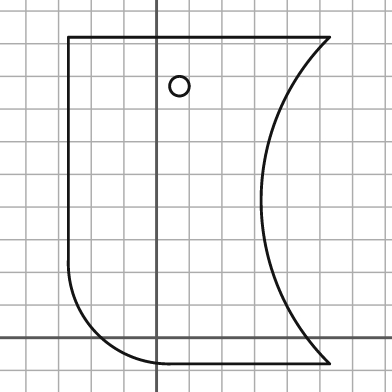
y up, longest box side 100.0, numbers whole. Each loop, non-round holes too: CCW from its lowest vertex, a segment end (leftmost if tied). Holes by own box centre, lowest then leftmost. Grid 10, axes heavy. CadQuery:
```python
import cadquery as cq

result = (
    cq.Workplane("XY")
    .moveTo(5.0, -8.0)
    .lineTo(53.0, -8.0)
    .threePointArc((32.0, 42.0), (53.0, 92.0))
    .lineTo(-27.0, 92.0)
    .lineTo(-27.0, 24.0)
    .threePointArc((-18.0, 1.0), (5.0, -8.0))
    .close()
    .moveTo(7.0, 77.0)
    .circle(3.0)
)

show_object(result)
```